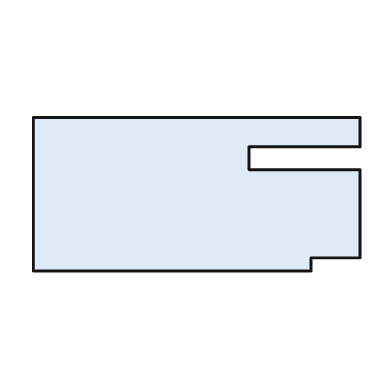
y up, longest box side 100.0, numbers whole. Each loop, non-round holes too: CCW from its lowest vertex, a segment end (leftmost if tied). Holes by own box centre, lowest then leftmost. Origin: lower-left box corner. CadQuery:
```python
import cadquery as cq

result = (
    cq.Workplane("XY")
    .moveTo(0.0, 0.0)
    .lineTo(85.0, 0.0)
    .lineTo(85.0, 4.0)
    .lineTo(100.0, 4.0)
    .lineTo(100.0, 31.0)
    .lineTo(66.0, 31.0)
    .lineTo(66.0, 38.0)
    .lineTo(100.0, 38.0)
    .lineTo(100.0, 47.0)
    .lineTo(0.0, 47.0)
    .close()
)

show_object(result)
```